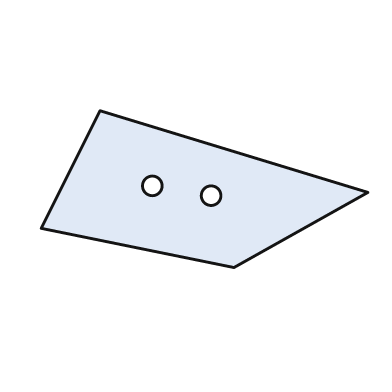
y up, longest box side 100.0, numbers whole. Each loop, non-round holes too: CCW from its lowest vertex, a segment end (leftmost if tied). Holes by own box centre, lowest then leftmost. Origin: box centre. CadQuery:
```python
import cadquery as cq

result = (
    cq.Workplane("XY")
    .moveTo(9.0, -24.0)
    .lineTo(50.0, -1.0)
    .lineTo(-32.0, 24.0)
    .lineTo(-50.0, -12.0)
    .close()
    .moveTo(2.0, -2.0)
    .circle(3.0)
    .moveTo(-16.0, 1.0)
    .circle(3.0)
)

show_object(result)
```